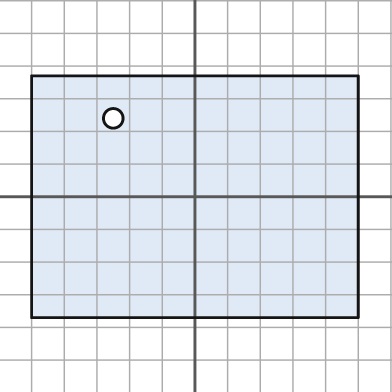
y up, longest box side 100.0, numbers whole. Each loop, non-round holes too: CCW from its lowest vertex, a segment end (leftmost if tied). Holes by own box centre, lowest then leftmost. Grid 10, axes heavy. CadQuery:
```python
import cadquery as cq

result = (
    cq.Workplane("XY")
    .moveTo(-50.0, -37.0)
    .lineTo(50.0, -37.0)
    .lineTo(50.0, 37.0)
    .lineTo(-50.0, 37.0)
    .close()
    .moveTo(-25.0, 24.0)
    .circle(3.0)
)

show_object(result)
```